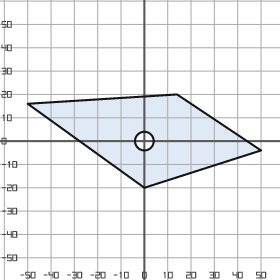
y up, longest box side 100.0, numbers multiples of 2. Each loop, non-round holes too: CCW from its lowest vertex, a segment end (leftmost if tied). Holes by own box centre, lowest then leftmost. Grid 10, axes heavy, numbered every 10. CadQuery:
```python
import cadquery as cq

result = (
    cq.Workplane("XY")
    .moveTo(0.0, -20.0)
    .lineTo(50.0, -4.0)
    .lineTo(14.0, 20.0)
    .lineTo(-50.0, 16.0)
    .close()
    .moveTo(0.0, 0.0)
    .circle(4.0)
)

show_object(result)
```